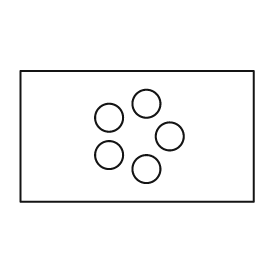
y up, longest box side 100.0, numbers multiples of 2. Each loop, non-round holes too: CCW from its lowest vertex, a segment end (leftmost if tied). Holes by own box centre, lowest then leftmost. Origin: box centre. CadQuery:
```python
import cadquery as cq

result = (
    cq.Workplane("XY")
    .moveTo(-50.0, -28.0)
    .lineTo(50.0, -28.0)
    .lineTo(50.0, 28.0)
    .lineTo(-50.0, 28.0)
    .close()
    .moveTo(4.0, -14.0)
    .circle(6.0)
    .moveTo(-12.0, -8.0)
    .circle(6.0)
    .moveTo(14.0, 0.0)
    .circle(6.0)
    .moveTo(-12.0, 8.0)
    .circle(6.0)
    .moveTo(4.0, 14.0)
    .circle(6.0)
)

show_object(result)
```